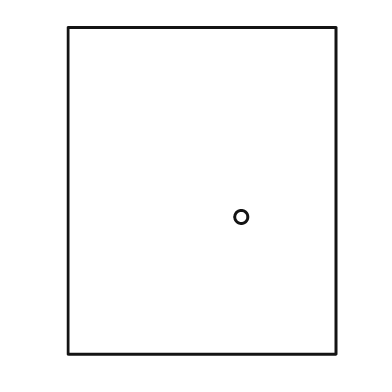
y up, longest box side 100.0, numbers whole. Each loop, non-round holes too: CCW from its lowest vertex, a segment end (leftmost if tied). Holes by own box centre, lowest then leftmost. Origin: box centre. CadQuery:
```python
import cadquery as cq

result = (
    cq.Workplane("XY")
    .moveTo(-41.0, -50.0)
    .lineTo(41.0, -50.0)
    .lineTo(41.0, 50.0)
    .lineTo(-41.0, 50.0)
    .close()
    .moveTo(12.0, -8.0)
    .circle(2.0)
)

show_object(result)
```